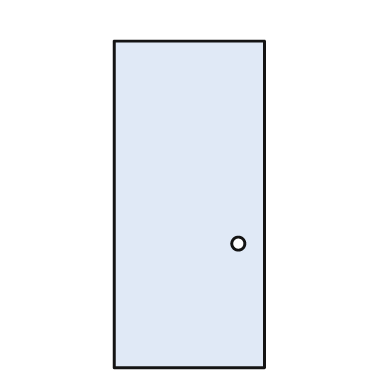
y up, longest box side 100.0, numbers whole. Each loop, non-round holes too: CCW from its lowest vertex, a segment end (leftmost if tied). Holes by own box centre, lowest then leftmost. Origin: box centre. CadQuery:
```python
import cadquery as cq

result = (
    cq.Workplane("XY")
    .moveTo(-23.0, -50.0)
    .lineTo(23.0, -50.0)
    .lineTo(23.0, 50.0)
    .lineTo(-23.0, 50.0)
    .close()
    .moveTo(15.0, -12.0)
    .circle(2.0)
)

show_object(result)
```